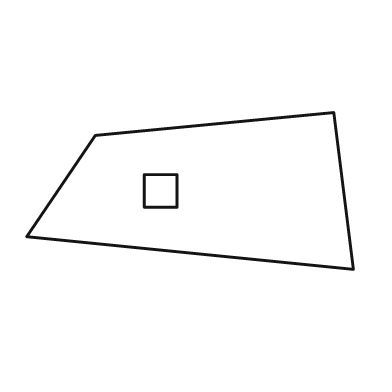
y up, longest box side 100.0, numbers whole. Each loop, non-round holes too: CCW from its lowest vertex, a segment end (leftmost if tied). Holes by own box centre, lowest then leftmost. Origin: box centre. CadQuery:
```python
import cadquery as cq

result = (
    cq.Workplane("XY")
    .moveTo(50.0, -24.0)
    .lineTo(44.0, 24.0)
    .lineTo(-29.0, 17.0)
    .lineTo(-50.0, -14.0)
    .close()
    .moveTo(-14.0, -5.0)
    .lineTo(-4.0, -5.0)
    .lineTo(-4.0, 5.0)
    .lineTo(-14.0, 5.0)
    .close()
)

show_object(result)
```